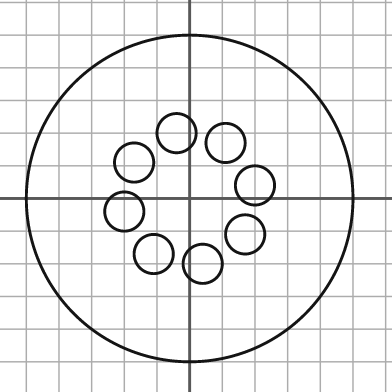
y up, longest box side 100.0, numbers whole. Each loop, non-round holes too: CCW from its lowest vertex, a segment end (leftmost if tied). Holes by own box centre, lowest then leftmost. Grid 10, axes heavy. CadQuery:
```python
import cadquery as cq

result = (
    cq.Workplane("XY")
    .moveTo(0.0, 0.0)
    .circle(50.0)
    .moveTo(4.0, -20.0)
    .circle(6.0)
    .moveTo(-11.0, -17.0)
    .circle(6.0)
    .moveTo(17.0, -11.0)
    .circle(6.0)
    .moveTo(-20.0, -4.0)
    .circle(6.0)
    .moveTo(20.0, 4.0)
    .circle(6.0)
    .moveTo(-17.0, 11.0)
    .circle(6.0)
    .moveTo(11.0, 17.0)
    .circle(6.0)
    .moveTo(-4.0, 20.0)
    .circle(6.0)
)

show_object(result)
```